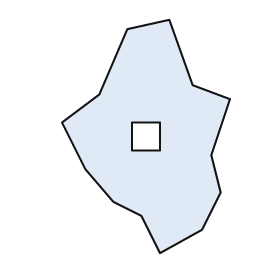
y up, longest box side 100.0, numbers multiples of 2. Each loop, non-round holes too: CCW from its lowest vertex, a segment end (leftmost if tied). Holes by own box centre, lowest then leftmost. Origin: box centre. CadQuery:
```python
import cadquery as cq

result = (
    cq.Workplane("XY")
    .moveTo(6.0, -50.0)
    .lineTo(24.0, -40.0)
    .lineTo(32.0, -24.0)
    .lineTo(28.0, -8.0)
    .lineTo(36.0, 16.0)
    .lineTo(20.0, 22.0)
    .lineTo(10.0, 50.0)
    .lineTo(-8.0, 46.0)
    .lineTo(-20.0, 18.0)
    .lineTo(-36.0, 6.0)
    .lineTo(-26.0, -14.0)
    .lineTo(-14.0, -28.0)
    .lineTo(-2.0, -34.0)
    .close()
    .moveTo(-6.0, -6.0)
    .lineTo(6.0, -6.0)
    .lineTo(6.0, 6.0)
    .lineTo(-6.0, 6.0)
    .close()
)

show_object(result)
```